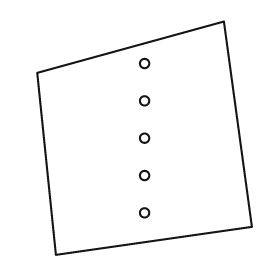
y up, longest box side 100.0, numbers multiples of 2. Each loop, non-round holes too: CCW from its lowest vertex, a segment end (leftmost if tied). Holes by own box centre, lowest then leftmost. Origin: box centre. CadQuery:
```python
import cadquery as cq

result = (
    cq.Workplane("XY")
    .moveTo(-38.0, -50.0)
    .lineTo(46.0, -38.0)
    .lineTo(34.0, 50.0)
    .lineTo(-46.0, 28.0)
    .close()
    .moveTo(0.0, -32.0)
    .circle(2.0)
    .moveTo(0.0, -16.0)
    .circle(2.0)
    .moveTo(0.0, 0.0)
    .circle(2.0)
    .moveTo(0.0, 16.0)
    .circle(2.0)
    .moveTo(0.0, 32.0)
    .circle(2.0)
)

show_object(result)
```